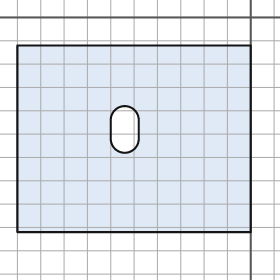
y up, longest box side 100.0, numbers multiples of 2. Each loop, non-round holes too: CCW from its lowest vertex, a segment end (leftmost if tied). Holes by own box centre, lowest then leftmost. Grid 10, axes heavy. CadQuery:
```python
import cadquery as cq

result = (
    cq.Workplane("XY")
    .moveTo(-100.0, -92.0)
    .lineTo(0.0, -92.0)
    .lineTo(0.0, -12.0)
    .lineTo(-100.0, -12.0)
    .close()
    .moveTo(-60.0, -52.0)
    .threePointArc((-54.0, -58.0), (-48.0, -52.0))
    .lineTo(-48.0, -44.0)
    .threePointArc((-54.0, -38.0), (-60.0, -44.0))
    .close()
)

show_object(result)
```